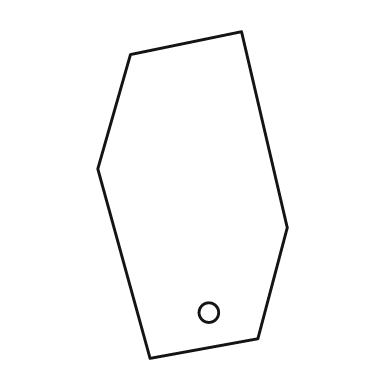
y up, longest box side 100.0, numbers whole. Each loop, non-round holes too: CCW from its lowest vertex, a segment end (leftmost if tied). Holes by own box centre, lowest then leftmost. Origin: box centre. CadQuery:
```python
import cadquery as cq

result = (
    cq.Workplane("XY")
    .moveTo(-13.0, -50.0)
    .lineTo(20.0, -44.0)
    .lineTo(29.0, -10.0)
    .lineTo(15.0, 50.0)
    .lineTo(-19.0, 43.0)
    .lineTo(-29.0, 8.0)
    .close()
    .moveTo(5.0, -36.0)
    .circle(3.0)
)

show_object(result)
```